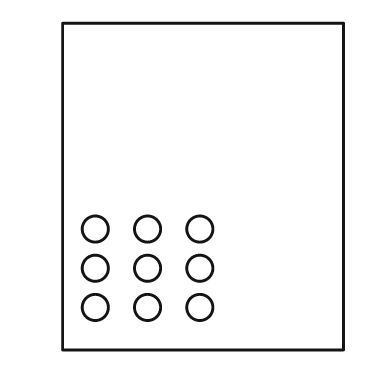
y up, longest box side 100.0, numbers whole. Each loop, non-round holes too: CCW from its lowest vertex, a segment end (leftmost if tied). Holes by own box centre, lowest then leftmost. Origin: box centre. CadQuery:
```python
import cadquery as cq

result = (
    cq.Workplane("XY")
    .moveTo(-43.0, -50.0)
    .lineTo(43.0, -50.0)
    .lineTo(43.0, 50.0)
    .lineTo(-43.0, 50.0)
    .close()
    .moveTo(-33.0, -37.0)
    .circle(4.0)
    .moveTo(-17.0, -37.0)
    .circle(4.0)
    .moveTo(-1.0, -37.0)
    .circle(4.0)
    .moveTo(-33.0, -25.0)
    .circle(4.0)
    .moveTo(-17.0, -25.0)
    .circle(4.0)
    .moveTo(-1.0, -25.0)
    .circle(4.0)
    .moveTo(-33.0, -13.0)
    .circle(4.0)
    .moveTo(-17.0, -13.0)
    .circle(4.0)
    .moveTo(-1.0, -13.0)
    .circle(4.0)
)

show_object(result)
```